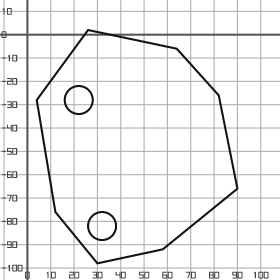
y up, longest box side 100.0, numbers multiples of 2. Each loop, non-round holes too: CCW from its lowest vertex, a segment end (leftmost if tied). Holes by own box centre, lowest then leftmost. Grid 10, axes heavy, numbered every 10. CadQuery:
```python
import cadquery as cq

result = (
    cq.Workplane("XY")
    .moveTo(30.0, -98.0)
    .lineTo(58.0, -92.0)
    .lineTo(90.0, -66.0)
    .lineTo(82.0, -26.0)
    .lineTo(64.0, -6.0)
    .lineTo(26.0, 2.0)
    .lineTo(4.0, -28.0)
    .lineTo(12.0, -76.0)
    .close()
    .moveTo(32.0, -82.0)
    .circle(6.0)
    .moveTo(22.0, -28.0)
    .circle(6.0)
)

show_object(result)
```